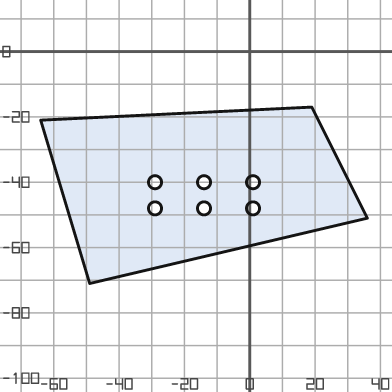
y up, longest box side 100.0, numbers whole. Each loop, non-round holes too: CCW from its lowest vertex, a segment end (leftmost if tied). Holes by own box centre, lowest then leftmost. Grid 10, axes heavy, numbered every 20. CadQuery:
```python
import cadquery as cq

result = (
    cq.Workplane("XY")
    .moveTo(-49.0, -71.0)
    .lineTo(36.0, -51.0)
    .lineTo(19.0, -17.0)
    .lineTo(-64.0, -21.0)
    .close()
    .moveTo(-29.0, -48.0)
    .circle(2.0)
    .moveTo(-14.0, -48.0)
    .circle(2.0)
    .moveTo(1.0, -48.0)
    .circle(2.0)
    .moveTo(-29.0, -40.0)
    .circle(2.0)
    .moveTo(-14.0, -40.0)
    .circle(2.0)
    .moveTo(1.0, -40.0)
    .circle(2.0)
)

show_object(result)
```